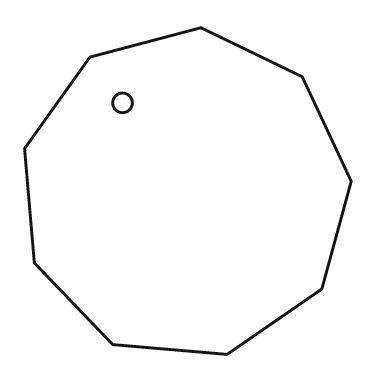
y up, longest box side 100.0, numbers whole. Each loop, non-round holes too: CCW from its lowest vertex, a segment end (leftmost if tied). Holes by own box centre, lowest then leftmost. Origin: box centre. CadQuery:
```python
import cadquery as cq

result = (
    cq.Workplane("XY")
    .moveTo(12.0, -50.0)
    .lineTo(41.0, -30.0)
    .lineTo(50.0, 3.0)
    .lineTo(35.0, 35.0)
    .lineTo(4.0, 50.0)
    .lineTo(-30.0, 41.0)
    .lineTo(-50.0, 13.0)
    .lineTo(-47.0, -22.0)
    .lineTo(-23.0, -47.0)
    .close()
    .moveTo(-20.0, 27.0)
    .circle(3.0)
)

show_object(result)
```